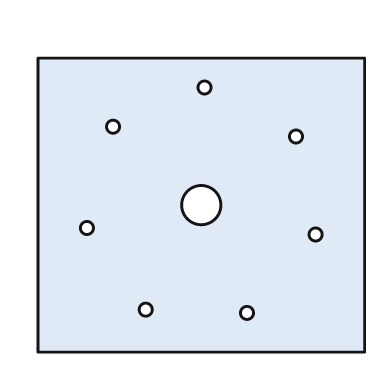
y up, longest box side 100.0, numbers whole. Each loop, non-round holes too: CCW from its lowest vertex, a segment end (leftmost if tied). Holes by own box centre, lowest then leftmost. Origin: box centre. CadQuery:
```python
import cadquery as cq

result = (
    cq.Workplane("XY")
    .moveTo(-50.0, -45.0)
    .lineTo(50.0, -45.0)
    .lineTo(50.0, 45.0)
    .lineTo(-50.0, 45.0)
    .close()
    .moveTo(14.0, -33.0)
    .circle(2.0)
    .moveTo(-17.0, -32.0)
    .circle(2.0)
    .moveTo(35.0, -9.0)
    .circle(2.0)
    .moveTo(-35.0, -7.0)
    .circle(2.0)
    .moveTo(0.0, 0.0)
    .circle(6.0)
    .moveTo(29.0, 21.0)
    .circle(2.0)
    .moveTo(-27.0, 24.0)
    .circle(2.0)
    .moveTo(1.0, 36.0)
    .circle(2.0)
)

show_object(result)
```